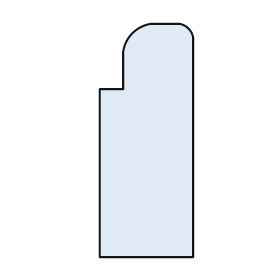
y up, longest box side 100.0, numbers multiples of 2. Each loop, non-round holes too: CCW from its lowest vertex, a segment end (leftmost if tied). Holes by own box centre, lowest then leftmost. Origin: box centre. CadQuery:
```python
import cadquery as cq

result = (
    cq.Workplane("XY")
    .moveTo(-20.0, -50.0)
    .lineTo(20.0, -50.0)
    .lineTo(20.0, 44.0)
    .threePointArc((18.0, 48.0), (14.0, 50.0))
    .lineTo(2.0, 50.0)
    .threePointArc((-6.0, 46.0), (-10.0, 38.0))
    .lineTo(-10.0, 22.0)
    .lineTo(-20.0, 22.0)
    .close()
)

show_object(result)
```